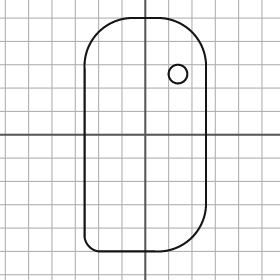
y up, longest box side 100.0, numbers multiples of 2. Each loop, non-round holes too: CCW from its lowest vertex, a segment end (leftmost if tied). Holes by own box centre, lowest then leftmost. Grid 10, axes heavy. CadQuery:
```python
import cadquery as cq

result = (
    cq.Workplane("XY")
    .moveTo(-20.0, -50.0)
    .lineTo(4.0, -50.0)
    .threePointArc((20.0, -44.0), (26.0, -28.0))
    .lineTo(26.0, 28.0)
    .threePointArc((20.0, 44.0), (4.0, 50.0))
    .lineTo(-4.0, 50.0)
    .threePointArc((-20.0, 44.0), (-26.0, 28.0))
    .lineTo(-26.0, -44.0)
    .threePointArc((-24.0, -48.0), (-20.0, -50.0))
    .close()
    .moveTo(14.0, 26.0)
    .circle(4.0)
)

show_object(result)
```